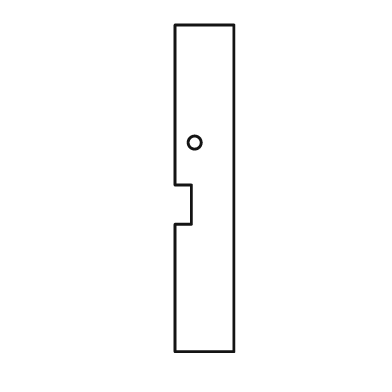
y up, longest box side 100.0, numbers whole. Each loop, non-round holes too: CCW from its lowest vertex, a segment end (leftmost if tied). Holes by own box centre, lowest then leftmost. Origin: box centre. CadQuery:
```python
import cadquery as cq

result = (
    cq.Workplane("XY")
    .moveTo(-9.0, -50.0)
    .lineTo(9.0, -50.0)
    .lineTo(9.0, 50.0)
    .lineTo(-9.0, 50.0)
    .lineTo(-9.0, 1.0)
    .lineTo(-4.0, 1.0)
    .lineTo(-4.0, -11.0)
    .lineTo(-9.0, -11.0)
    .close()
    .moveTo(-3.0, 14.0)
    .circle(2.0)
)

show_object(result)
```